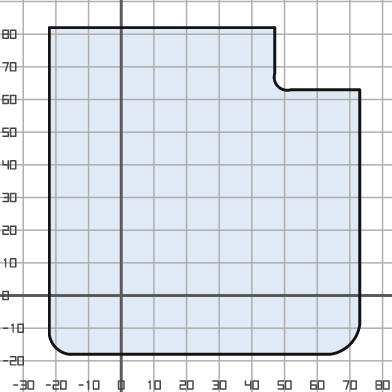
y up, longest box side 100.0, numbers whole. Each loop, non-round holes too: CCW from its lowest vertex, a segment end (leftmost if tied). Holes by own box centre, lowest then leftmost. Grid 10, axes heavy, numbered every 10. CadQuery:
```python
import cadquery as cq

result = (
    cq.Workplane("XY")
    .moveTo(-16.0, -18.0)
    .lineTo(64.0, -18.0)
    .threePointArc((70.0, -15.0), (73.0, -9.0))
    .lineTo(73.0, 63.0)
    .lineTo(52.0, 63.0)
    .threePointArc((48.0, 64.0), (47.0, 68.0))
    .lineTo(47.0, 82.0)
    .lineTo(-22.0, 82.0)
    .lineTo(-22.0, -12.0)
    .threePointArc((-20.0, -16.0), (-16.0, -18.0))
    .close()
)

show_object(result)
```